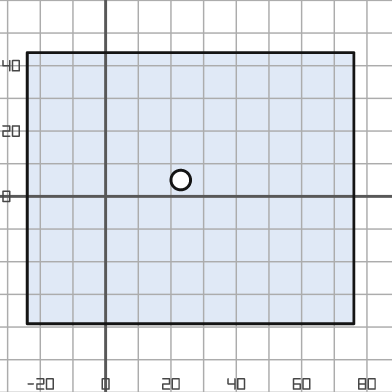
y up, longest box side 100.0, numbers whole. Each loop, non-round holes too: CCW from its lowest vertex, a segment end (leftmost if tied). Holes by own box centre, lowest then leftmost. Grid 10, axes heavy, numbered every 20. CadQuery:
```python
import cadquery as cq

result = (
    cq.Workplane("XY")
    .moveTo(-24.0, -39.0)
    .lineTo(76.0, -39.0)
    .lineTo(76.0, 44.0)
    .lineTo(-24.0, 44.0)
    .close()
    .moveTo(23.0, 5.0)
    .circle(3.0)
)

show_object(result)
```